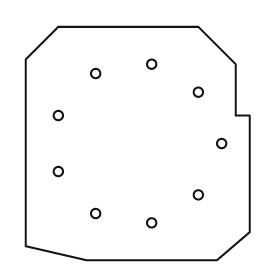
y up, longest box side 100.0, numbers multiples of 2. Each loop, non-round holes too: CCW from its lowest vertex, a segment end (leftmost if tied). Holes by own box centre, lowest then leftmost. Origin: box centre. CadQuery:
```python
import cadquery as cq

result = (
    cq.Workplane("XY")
    .moveTo(-22.0, -50.0)
    .lineTo(34.0, -50.0)
    .lineTo(48.0, -38.0)
    .lineTo(48.0, 12.0)
    .lineTo(42.0, 12.0)
    .lineTo(42.0, 34.0)
    .lineTo(26.0, 50.0)
    .lineTo(-34.0, 50.0)
    .lineTo(-48.0, 36.0)
    .lineTo(-48.0, -44.0)
    .close()
    .moveTo(6.0, -34.0)
    .circle(2.0)
    .moveTo(-18.0, -30.0)
    .circle(2.0)
    .moveTo(26.0, -22.0)
    .circle(2.0)
    .moveTo(-34.0, -12.0)
    .circle(2.0)
    .moveTo(36.0, 0.0)
    .circle(2.0)
    .moveTo(-34.0, 12.0)
    .circle(2.0)
    .moveTo(26.0, 22.0)
    .circle(2.0)
    .moveTo(-18.0, 30.0)
    .circle(2.0)
    .moveTo(6.0, 34.0)
    .circle(2.0)
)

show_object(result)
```